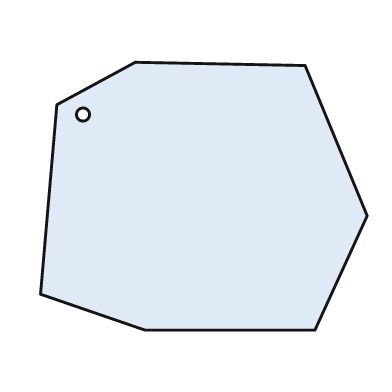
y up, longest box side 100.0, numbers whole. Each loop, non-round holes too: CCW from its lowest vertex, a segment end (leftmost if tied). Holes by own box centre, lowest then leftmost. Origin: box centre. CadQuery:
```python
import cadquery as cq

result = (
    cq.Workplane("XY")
    .moveTo(-18.0, -41.0)
    .lineTo(34.0, -41.0)
    .lineTo(50.0, -6.0)
    .lineTo(31.0, 40.0)
    .lineTo(-21.0, 41.0)
    .lineTo(-45.0, 28.0)
    .lineTo(-50.0, -30.0)
    .close()
    .moveTo(-37.0, 25.0)
    .circle(2.0)
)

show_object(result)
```